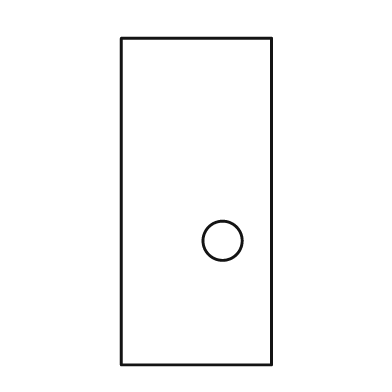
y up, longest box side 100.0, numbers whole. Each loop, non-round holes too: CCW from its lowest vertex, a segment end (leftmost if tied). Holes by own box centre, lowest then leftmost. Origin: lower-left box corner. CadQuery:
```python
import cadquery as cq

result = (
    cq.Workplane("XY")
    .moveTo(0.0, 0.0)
    .lineTo(46.0, 0.0)
    .lineTo(46.0, 100.0)
    .lineTo(0.0, 100.0)
    .close()
    .moveTo(31.0, 38.0)
    .circle(6.0)
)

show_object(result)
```